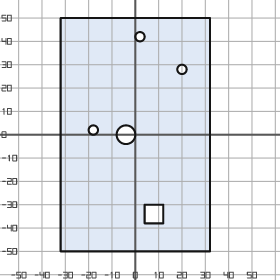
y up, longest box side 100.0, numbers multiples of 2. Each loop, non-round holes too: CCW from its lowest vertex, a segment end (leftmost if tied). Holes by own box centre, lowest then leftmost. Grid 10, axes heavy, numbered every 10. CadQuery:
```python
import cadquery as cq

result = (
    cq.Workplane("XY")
    .moveTo(-32.0, -50.0)
    .lineTo(32.0, -50.0)
    .lineTo(32.0, 50.0)
    .lineTo(-32.0, 50.0)
    .close()
    .moveTo(4.0, -38.0)
    .lineTo(12.0, -38.0)
    .lineTo(12.0, -30.0)
    .lineTo(4.0, -30.0)
    .close()
    .moveTo(-4.0, 0.0)
    .circle(4.0)
    .moveTo(-18.0, 2.0)
    .circle(2.0)
    .moveTo(20.0, 28.0)
    .circle(2.0)
    .moveTo(2.0, 42.0)
    .circle(2.0)
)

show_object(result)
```